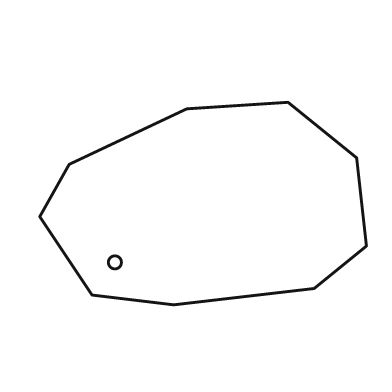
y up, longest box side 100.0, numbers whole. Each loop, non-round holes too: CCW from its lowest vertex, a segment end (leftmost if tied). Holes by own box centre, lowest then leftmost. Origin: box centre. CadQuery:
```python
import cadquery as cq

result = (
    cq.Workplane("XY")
    .moveTo(-9.0, -31.0)
    .lineTo(34.0, -26.0)
    .lineTo(50.0, -13.0)
    .lineTo(47.0, 14.0)
    .lineTo(26.0, 31.0)
    .lineTo(-5.0, 29.0)
    .lineTo(-41.0, 12.0)
    .lineTo(-50.0, -4.0)
    .lineTo(-34.0, -28.0)
    .close()
    .moveTo(-27.0, -18.0)
    .circle(2.0)
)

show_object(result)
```